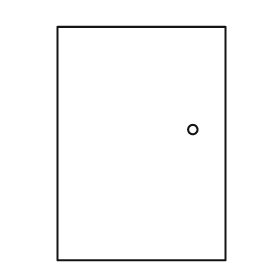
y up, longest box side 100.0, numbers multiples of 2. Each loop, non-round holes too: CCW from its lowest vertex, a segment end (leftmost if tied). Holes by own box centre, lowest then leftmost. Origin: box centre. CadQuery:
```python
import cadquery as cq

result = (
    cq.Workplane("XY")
    .moveTo(-36.0, -50.0)
    .lineTo(36.0, -50.0)
    .lineTo(36.0, 50.0)
    .lineTo(-36.0, 50.0)
    .close()
    .moveTo(22.0, 6.0)
    .circle(2.0)
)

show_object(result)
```